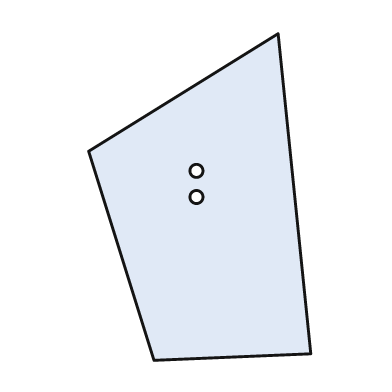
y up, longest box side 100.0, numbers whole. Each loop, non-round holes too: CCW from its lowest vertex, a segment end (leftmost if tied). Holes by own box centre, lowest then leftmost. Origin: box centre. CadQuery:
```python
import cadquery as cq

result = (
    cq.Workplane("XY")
    .moveTo(-14.0, -50.0)
    .lineTo(34.0, -48.0)
    .lineTo(24.0, 50.0)
    .lineTo(-34.0, 14.0)
    .close()
    .moveTo(-1.0, 0.0)
    .circle(2.0)
    .moveTo(-1.0, 8.0)
    .circle(2.0)
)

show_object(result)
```